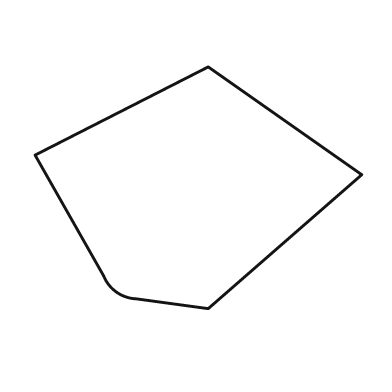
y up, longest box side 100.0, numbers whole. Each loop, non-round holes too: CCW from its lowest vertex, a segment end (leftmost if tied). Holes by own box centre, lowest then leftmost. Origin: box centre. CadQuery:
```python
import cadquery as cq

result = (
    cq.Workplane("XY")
    .moveTo(3.0, -37.0)
    .lineTo(50.0, 4.0)
    .lineTo(3.0, 37.0)
    .lineTo(-50.0, 10.0)
    .lineTo(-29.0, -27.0)
    .threePointArc((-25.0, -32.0), (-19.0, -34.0))
    .close()
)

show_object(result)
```